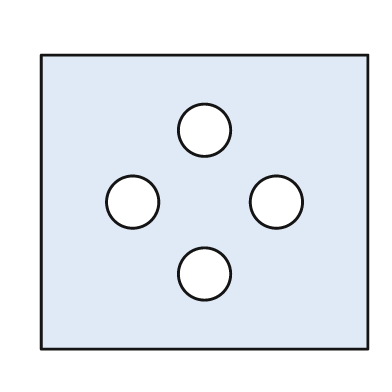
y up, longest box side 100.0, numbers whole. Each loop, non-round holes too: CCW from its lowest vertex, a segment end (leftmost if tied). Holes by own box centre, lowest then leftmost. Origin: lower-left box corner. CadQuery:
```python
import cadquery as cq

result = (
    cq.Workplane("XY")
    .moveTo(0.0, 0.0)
    .lineTo(100.0, 0.0)
    .lineTo(100.0, 90.0)
    .lineTo(0.0, 90.0)
    .close()
    .moveTo(50.0, 23.0)
    .circle(8.0)
    .moveTo(28.0, 45.0)
    .circle(8.0)
    .moveTo(72.0, 45.0)
    .circle(8.0)
    .moveTo(50.0, 67.0)
    .circle(8.0)
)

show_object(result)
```